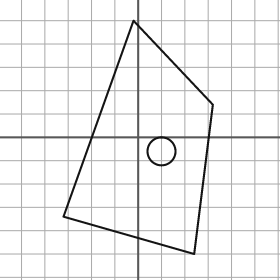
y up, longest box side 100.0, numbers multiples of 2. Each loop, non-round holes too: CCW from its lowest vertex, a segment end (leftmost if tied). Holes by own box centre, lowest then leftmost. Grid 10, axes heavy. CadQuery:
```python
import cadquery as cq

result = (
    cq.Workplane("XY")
    .moveTo(24.0, -50.0)
    .lineTo(32.0, 14.0)
    .lineTo(-2.0, 50.0)
    .lineTo(-32.0, -34.0)
    .close()
    .moveTo(10.0, -6.0)
    .circle(6.0)
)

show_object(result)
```